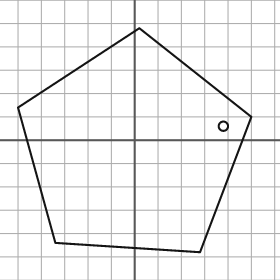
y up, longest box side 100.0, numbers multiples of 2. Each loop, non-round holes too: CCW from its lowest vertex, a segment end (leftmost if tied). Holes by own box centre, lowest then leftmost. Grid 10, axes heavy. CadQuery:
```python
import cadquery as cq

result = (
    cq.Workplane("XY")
    .moveTo(28.0, -48.0)
    .lineTo(50.0, 10.0)
    .lineTo(2.0, 48.0)
    .lineTo(-50.0, 14.0)
    .lineTo(-34.0, -44.0)
    .close()
    .moveTo(38.0, 6.0)
    .circle(2.0)
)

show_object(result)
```